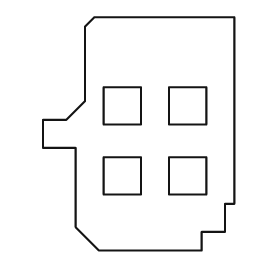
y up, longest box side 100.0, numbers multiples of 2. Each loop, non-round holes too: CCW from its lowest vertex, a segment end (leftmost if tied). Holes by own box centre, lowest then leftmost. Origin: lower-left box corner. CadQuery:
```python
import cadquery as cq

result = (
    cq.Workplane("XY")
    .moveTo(24.0, 0.0)
    .lineTo(68.0, 0.0)
    .lineTo(68.0, 8.0)
    .lineTo(78.0, 8.0)
    .lineTo(78.0, 20.0)
    .lineTo(82.0, 20.0)
    .lineTo(82.0, 100.0)
    .lineTo(22.0, 100.0)
    .lineTo(18.0, 96.0)
    .lineTo(18.0, 64.0)
    .lineTo(10.0, 56.0)
    .lineTo(0.0, 56.0)
    .lineTo(0.0, 44.0)
    .lineTo(14.0, 44.0)
    .lineTo(14.0, 10.0)
    .close()
    .moveTo(26.0, 24.0)
    .lineTo(42.0, 24.0)
    .lineTo(42.0, 40.0)
    .lineTo(26.0, 40.0)
    .close()
    .moveTo(54.0, 24.0)
    .lineTo(70.0, 24.0)
    .lineTo(70.0, 40.0)
    .lineTo(54.0, 40.0)
    .close()
    .moveTo(26.0, 54.0)
    .lineTo(42.0, 54.0)
    .lineTo(42.0, 70.0)
    .lineTo(26.0, 70.0)
    .close()
    .moveTo(54.0, 54.0)
    .lineTo(70.0, 54.0)
    .lineTo(70.0, 70.0)
    .lineTo(54.0, 70.0)
    .close()
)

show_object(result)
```